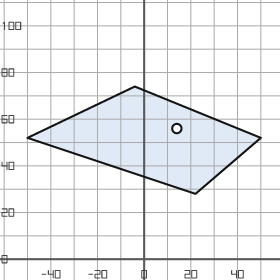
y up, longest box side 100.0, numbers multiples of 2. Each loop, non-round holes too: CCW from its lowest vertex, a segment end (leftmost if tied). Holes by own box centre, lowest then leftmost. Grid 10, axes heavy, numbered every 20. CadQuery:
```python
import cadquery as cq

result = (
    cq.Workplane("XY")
    .moveTo(22.0, 28.0)
    .lineTo(50.0, 52.0)
    .lineTo(-4.0, 74.0)
    .lineTo(-50.0, 52.0)
    .close()
    .moveTo(14.0, 56.0)
    .circle(2.0)
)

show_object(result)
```